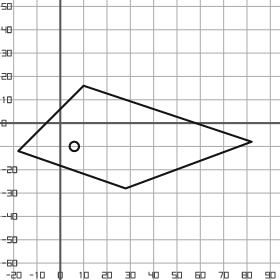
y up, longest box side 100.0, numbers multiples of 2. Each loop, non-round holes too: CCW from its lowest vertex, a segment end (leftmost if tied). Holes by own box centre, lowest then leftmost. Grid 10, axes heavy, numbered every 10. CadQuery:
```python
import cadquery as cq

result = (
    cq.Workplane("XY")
    .moveTo(28.0, -28.0)
    .lineTo(82.0, -8.0)
    .lineTo(10.0, 16.0)
    .lineTo(-18.0, -12.0)
    .close()
    .moveTo(6.0, -10.0)
    .circle(2.0)
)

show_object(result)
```